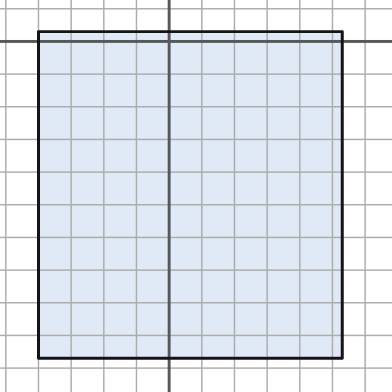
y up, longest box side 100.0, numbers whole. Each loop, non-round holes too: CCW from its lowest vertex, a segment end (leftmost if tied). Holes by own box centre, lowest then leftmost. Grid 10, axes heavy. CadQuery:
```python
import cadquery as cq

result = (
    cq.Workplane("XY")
    .moveTo(-40.0, -97.0)
    .lineTo(53.0, -97.0)
    .lineTo(53.0, 3.0)
    .lineTo(-40.0, 3.0)
    .close()
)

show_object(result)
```